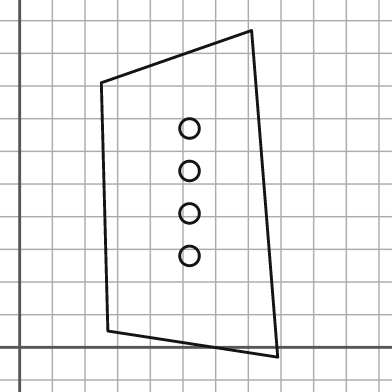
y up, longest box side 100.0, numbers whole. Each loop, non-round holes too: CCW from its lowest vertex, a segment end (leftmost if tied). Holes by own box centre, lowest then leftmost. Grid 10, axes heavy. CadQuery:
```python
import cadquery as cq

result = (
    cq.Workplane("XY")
    .moveTo(79.0, -3.0)
    .lineTo(71.0, 97.0)
    .lineTo(25.0, 81.0)
    .lineTo(27.0, 5.0)
    .close()
    .moveTo(52.0, 28.0)
    .circle(3.0)
    .moveTo(52.0, 41.0)
    .circle(3.0)
    .moveTo(52.0, 54.0)
    .circle(3.0)
    .moveTo(52.0, 67.0)
    .circle(3.0)
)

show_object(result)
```